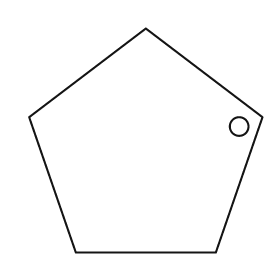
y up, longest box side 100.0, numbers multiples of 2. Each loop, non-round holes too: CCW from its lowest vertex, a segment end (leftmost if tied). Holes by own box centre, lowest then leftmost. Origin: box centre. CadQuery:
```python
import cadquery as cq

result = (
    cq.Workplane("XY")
    .moveTo(-30.0, -48.0)
    .lineTo(30.0, -48.0)
    .lineTo(50.0, 10.0)
    .lineTo(0.0, 48.0)
    .lineTo(-50.0, 10.0)
    .close()
    .moveTo(40.0, 6.0)
    .circle(4.0)
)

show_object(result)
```